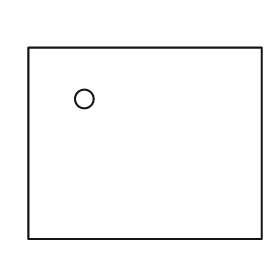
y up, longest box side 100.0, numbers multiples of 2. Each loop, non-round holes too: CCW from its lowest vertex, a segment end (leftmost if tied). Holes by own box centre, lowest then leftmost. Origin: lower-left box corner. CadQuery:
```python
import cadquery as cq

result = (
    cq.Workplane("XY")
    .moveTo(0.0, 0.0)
    .lineTo(100.0, 0.0)
    .lineTo(100.0, 82.0)
    .lineTo(0.0, 82.0)
    .close()
    .moveTo(24.0, 60.0)
    .circle(4.0)
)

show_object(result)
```